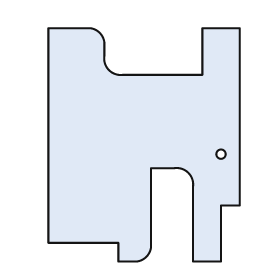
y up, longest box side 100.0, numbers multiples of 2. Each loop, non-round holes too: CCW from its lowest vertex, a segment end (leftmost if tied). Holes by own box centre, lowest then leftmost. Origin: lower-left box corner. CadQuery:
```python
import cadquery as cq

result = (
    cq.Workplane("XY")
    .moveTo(30.0, 0.0)
    .lineTo(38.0, 0.0)
    .threePointArc((42.0, 2.0), (44.0, 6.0))
    .lineTo(44.0, 40.0)
    .lineTo(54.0, 40.0)
    .threePointArc((60.0, 38.0), (62.0, 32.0))
    .lineTo(62.0, 0.0)
    .lineTo(74.0, 0.0)
    .lineTo(74.0, 24.0)
    .lineTo(82.0, 24.0)
    .lineTo(82.0, 100.0)
    .lineTo(66.0, 100.0)
    .lineTo(66.0, 80.0)
    .lineTo(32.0, 80.0)
    .threePointArc((26.0, 82.0), (24.0, 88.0))
    .lineTo(24.0, 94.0)
    .threePointArc((22.0, 98.0), (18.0, 100.0))
    .lineTo(0.0, 100.0)
    .lineTo(0.0, 8.0)
    .lineTo(30.0, 8.0)
    .close()
    .moveTo(74.0, 46.0)
    .circle(2.0)
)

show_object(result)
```